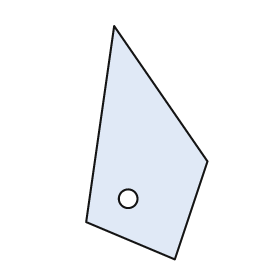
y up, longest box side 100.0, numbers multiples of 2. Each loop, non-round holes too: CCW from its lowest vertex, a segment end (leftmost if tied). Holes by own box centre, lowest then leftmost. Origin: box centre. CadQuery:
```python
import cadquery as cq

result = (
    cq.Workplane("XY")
    .moveTo(12.0, -50.0)
    .lineTo(26.0, -8.0)
    .lineTo(-14.0, 50.0)
    .lineTo(-26.0, -34.0)
    .close()
    .moveTo(-8.0, -24.0)
    .circle(4.0)
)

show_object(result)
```